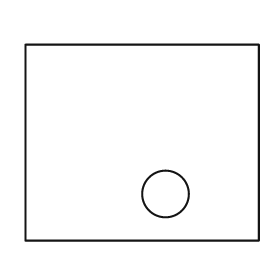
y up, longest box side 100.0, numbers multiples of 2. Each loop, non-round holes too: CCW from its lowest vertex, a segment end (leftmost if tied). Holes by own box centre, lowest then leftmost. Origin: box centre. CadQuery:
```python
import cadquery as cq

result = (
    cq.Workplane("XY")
    .moveTo(-50.0, -42.0)
    .lineTo(50.0, -42.0)
    .lineTo(50.0, 42.0)
    .lineTo(-50.0, 42.0)
    .close()
    .moveTo(10.0, -22.0)
    .circle(10.0)
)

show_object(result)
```